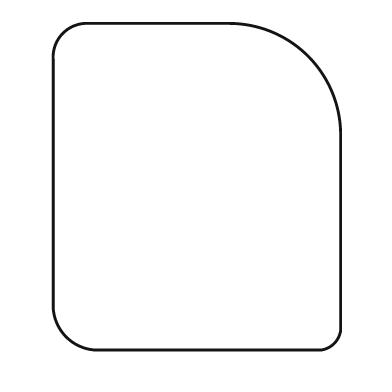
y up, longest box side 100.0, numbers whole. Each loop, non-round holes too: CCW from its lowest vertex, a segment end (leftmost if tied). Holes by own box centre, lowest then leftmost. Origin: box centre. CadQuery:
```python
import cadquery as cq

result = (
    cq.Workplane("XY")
    .moveTo(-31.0, -50.0)
    .lineTo(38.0, -50.0)
    .threePointArc((42.0, -48.0), (44.0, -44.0))
    .lineTo(44.0, 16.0)
    .threePointArc((34.0, 40.0), (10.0, 50.0))
    .lineTo(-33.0, 50.0)
    .threePointArc((-41.0, 47.0), (-44.0, 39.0))
    .lineTo(-44.0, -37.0)
    .threePointArc((-40.0, -46.0), (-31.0, -50.0))
    .close()
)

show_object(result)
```